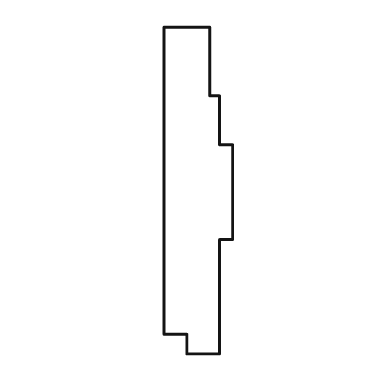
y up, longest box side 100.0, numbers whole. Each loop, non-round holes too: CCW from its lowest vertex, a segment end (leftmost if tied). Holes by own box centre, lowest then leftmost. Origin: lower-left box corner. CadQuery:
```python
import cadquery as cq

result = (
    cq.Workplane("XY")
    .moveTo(7.0, 0.0)
    .lineTo(17.0, 0.0)
    .lineTo(17.0, 35.0)
    .lineTo(21.0, 35.0)
    .lineTo(21.0, 64.0)
    .lineTo(17.0, 64.0)
    .lineTo(17.0, 79.0)
    .lineTo(14.0, 79.0)
    .lineTo(14.0, 100.0)
    .lineTo(0.0, 100.0)
    .lineTo(0.0, 6.0)
    .lineTo(7.0, 6.0)
    .close()
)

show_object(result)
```